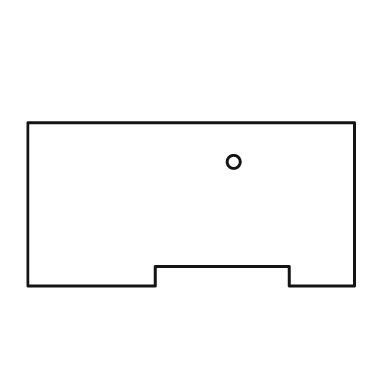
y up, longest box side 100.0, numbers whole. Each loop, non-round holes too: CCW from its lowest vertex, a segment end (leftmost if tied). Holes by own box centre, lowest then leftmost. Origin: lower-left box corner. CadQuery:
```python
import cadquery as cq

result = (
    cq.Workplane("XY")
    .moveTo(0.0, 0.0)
    .lineTo(39.0, 0.0)
    .lineTo(39.0, 6.0)
    .lineTo(80.0, 6.0)
    .lineTo(80.0, 0.0)
    .lineTo(100.0, 0.0)
    .lineTo(100.0, 50.0)
    .lineTo(0.0, 50.0)
    .close()
    .moveTo(63.0, 38.0)
    .circle(2.0)
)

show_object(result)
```